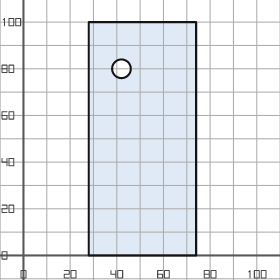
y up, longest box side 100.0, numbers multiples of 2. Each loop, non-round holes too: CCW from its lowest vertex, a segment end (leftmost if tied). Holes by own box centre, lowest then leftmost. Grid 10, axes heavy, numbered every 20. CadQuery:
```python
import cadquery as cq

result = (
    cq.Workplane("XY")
    .moveTo(28.0, 0.0)
    .lineTo(74.0, 0.0)
    .lineTo(74.0, 100.0)
    .lineTo(28.0, 100.0)
    .close()
    .moveTo(42.0, 80.0)
    .circle(4.0)
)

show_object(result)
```